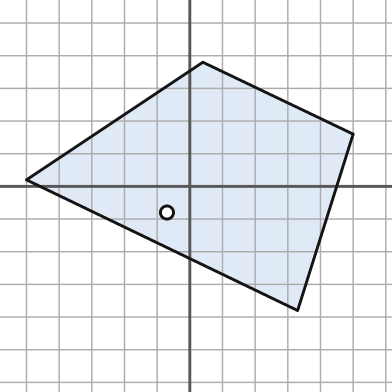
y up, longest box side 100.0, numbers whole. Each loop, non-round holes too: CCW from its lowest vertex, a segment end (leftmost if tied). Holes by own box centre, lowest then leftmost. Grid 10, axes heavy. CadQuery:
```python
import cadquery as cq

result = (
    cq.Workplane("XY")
    .moveTo(33.0, -38.0)
    .lineTo(50.0, 16.0)
    .lineTo(4.0, 38.0)
    .lineTo(-50.0, 2.0)
    .close()
    .moveTo(-7.0, -8.0)
    .circle(2.0)
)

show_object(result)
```